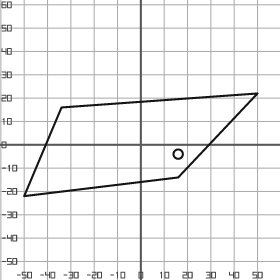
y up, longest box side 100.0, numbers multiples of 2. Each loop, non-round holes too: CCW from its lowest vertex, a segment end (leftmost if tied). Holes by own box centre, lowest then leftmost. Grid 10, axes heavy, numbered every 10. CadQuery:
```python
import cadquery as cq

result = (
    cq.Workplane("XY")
    .moveTo(-50.0, -22.0)
    .lineTo(16.0, -14.0)
    .lineTo(50.0, 22.0)
    .lineTo(-34.0, 16.0)
    .close()
    .moveTo(16.0, -4.0)
    .circle(2.0)
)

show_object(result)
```